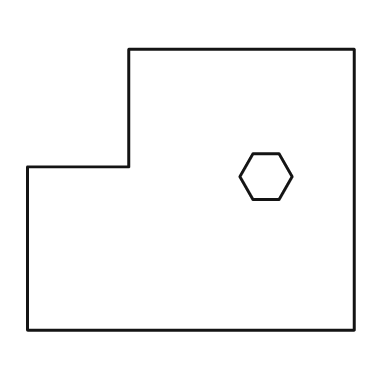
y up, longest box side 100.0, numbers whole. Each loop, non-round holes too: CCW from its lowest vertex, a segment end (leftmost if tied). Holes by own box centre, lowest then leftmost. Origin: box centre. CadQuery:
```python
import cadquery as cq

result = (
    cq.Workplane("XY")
    .moveTo(-50.0, -43.0)
    .lineTo(50.0, -43.0)
    .lineTo(50.0, 43.0)
    .lineTo(-19.0, 43.0)
    .lineTo(-19.0, 7.0)
    .lineTo(-50.0, 7.0)
    .close()
    .moveTo(19.0, -3.0)
    .lineTo(27.0, -3.0)
    .lineTo(31.0, 4.0)
    .lineTo(27.0, 11.0)
    .lineTo(19.0, 11.0)
    .lineTo(15.0, 4.0)
    .close()
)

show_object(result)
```